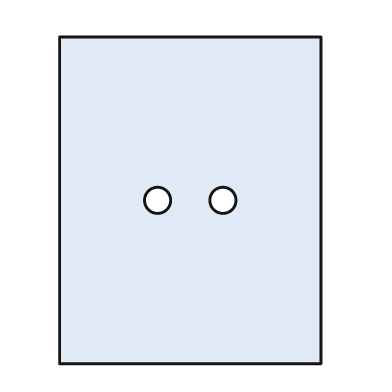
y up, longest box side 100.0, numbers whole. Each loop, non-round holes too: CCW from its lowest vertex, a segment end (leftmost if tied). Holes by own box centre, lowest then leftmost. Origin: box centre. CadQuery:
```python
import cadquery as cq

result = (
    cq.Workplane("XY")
    .moveTo(-40.0, -50.0)
    .lineTo(40.0, -50.0)
    .lineTo(40.0, 50.0)
    .lineTo(-40.0, 50.0)
    .close()
    .moveTo(-10.0, 0.0)
    .circle(4.0)
    .moveTo(10.0, 0.0)
    .circle(4.0)
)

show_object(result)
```